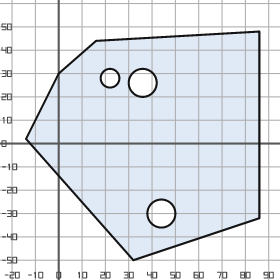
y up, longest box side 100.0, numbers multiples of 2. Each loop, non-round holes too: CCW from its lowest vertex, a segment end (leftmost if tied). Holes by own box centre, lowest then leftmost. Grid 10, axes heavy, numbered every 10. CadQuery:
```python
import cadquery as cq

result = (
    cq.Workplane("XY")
    .moveTo(32.0, -50.0)
    .lineTo(86.0, -32.0)
    .lineTo(86.0, 48.0)
    .lineTo(16.0, 44.0)
    .lineTo(0.0, 30.0)
    .lineTo(-14.0, 2.0)
    .close()
    .moveTo(44.0, -30.0)
    .circle(6.0)
    .moveTo(36.0, 26.0)
    .circle(6.0)
    .moveTo(22.0, 28.0)
    .circle(4.0)
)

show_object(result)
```